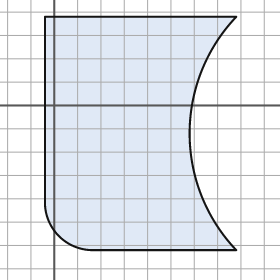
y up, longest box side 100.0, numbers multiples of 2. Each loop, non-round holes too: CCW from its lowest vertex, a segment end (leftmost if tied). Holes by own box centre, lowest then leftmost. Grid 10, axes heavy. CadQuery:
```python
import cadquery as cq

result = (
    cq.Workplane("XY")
    .moveTo(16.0, -62.0)
    .lineTo(78.0, -62.0)
    .threePointArc((58.0, -12.0), (78.0, 38.0))
    .lineTo(-4.0, 38.0)
    .lineTo(-4.0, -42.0)
    .threePointArc((2.0, -56.0), (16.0, -62.0))
    .close()
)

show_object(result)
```